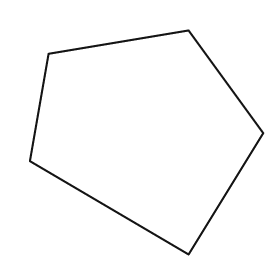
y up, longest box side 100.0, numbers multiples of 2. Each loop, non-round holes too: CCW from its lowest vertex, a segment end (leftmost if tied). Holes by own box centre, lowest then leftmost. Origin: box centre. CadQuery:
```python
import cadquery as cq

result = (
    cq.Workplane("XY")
    .moveTo(18.0, -48.0)
    .lineTo(50.0, 4.0)
    .lineTo(18.0, 48.0)
    .lineTo(-42.0, 38.0)
    .lineTo(-50.0, -8.0)
    .close()
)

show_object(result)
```